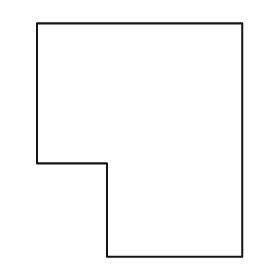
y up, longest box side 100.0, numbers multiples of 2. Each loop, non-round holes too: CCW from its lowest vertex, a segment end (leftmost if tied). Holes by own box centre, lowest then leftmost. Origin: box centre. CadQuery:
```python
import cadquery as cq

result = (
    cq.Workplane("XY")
    .moveTo(-14.0, -50.0)
    .lineTo(44.0, -50.0)
    .lineTo(44.0, 50.0)
    .lineTo(-44.0, 50.0)
    .lineTo(-44.0, -10.0)
    .lineTo(-14.0, -10.0)
    .close()
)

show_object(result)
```